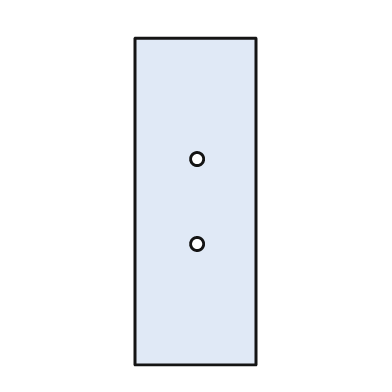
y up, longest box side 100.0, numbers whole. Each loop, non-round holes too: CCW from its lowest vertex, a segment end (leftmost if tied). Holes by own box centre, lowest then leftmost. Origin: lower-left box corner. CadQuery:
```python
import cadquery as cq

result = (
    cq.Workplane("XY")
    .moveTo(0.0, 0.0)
    .lineTo(37.0, 0.0)
    .lineTo(37.0, 100.0)
    .lineTo(0.0, 100.0)
    .close()
    .moveTo(19.0, 37.0)
    .circle(2.0)
    .moveTo(19.0, 63.0)
    .circle(2.0)
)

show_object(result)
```